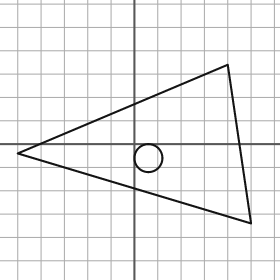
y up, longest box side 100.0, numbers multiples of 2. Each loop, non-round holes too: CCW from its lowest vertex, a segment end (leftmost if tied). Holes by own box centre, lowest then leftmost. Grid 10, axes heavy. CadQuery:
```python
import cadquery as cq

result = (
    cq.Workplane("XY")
    .moveTo(50.0, -34.0)
    .lineTo(40.0, 34.0)
    .lineTo(-50.0, -4.0)
    .close()
    .moveTo(6.0, -6.0)
    .circle(6.0)
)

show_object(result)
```